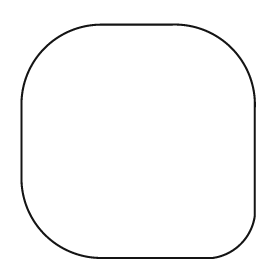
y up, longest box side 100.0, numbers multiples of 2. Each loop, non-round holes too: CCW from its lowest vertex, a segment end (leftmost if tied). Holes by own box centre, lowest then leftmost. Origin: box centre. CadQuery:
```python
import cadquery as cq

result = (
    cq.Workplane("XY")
    .moveTo(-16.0, -50.0)
    .lineTo(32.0, -50.0)
    .threePointArc((44.0, -44.0), (50.0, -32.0))
    .lineTo(50.0, 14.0)
    .threePointArc((40.0, 40.0), (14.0, 50.0))
    .lineTo(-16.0, 50.0)
    .threePointArc((-40.0, 40.0), (-50.0, 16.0))
    .lineTo(-50.0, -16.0)
    .threePointArc((-40.0, -40.0), (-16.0, -50.0))
    .close()
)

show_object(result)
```